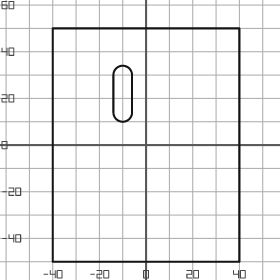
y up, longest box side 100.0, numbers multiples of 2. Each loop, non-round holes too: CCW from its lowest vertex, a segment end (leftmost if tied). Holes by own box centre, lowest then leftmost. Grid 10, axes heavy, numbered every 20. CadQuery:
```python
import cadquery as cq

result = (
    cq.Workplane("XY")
    .moveTo(-40.0, -50.0)
    .lineTo(40.0, -50.0)
    .lineTo(40.0, 50.0)
    .lineTo(-40.0, 50.0)
    .close()
    .moveTo(-14.0, 14.0)
    .threePointArc((-10.0, 10.0), (-6.0, 14.0))
    .lineTo(-6.0, 30.0)
    .threePointArc((-10.0, 34.0), (-14.0, 30.0))
    .close()
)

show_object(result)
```